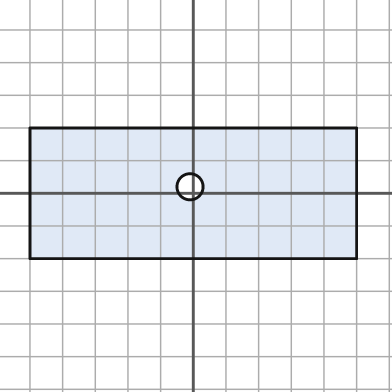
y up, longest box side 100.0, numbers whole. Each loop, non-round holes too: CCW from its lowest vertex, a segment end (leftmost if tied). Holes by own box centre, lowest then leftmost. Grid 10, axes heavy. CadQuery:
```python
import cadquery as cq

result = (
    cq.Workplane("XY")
    .moveTo(-50.0, -20.0)
    .lineTo(50.0, -20.0)
    .lineTo(50.0, 20.0)
    .lineTo(-50.0, 20.0)
    .close()
    .moveTo(-1.0, 2.0)
    .circle(4.0)
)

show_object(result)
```